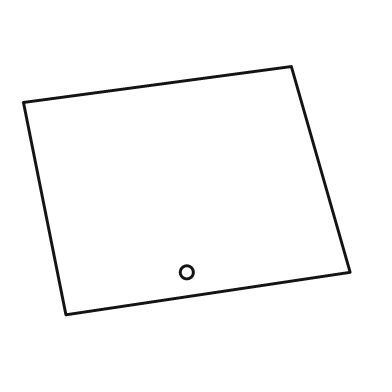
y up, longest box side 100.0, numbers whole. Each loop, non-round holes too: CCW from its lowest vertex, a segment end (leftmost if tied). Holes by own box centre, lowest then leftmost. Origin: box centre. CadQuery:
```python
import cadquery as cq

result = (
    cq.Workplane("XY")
    .moveTo(-37.0, -38.0)
    .lineTo(50.0, -25.0)
    .lineTo(32.0, 38.0)
    .lineTo(-50.0, 27.0)
    .close()
    .moveTo(0.0, -25.0)
    .circle(2.0)
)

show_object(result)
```